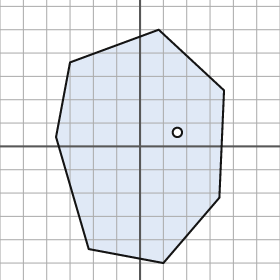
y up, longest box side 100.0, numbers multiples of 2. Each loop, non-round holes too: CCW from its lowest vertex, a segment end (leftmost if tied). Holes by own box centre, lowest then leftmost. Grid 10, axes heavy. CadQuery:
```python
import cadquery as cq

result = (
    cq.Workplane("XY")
    .moveTo(10.0, -50.0)
    .lineTo(34.0, -22.0)
    .lineTo(36.0, 24.0)
    .lineTo(8.0, 50.0)
    .lineTo(-30.0, 36.0)
    .lineTo(-36.0, 4.0)
    .lineTo(-22.0, -44.0)
    .close()
    .moveTo(16.0, 6.0)
    .circle(2.0)
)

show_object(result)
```